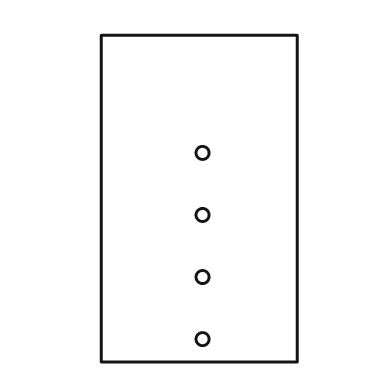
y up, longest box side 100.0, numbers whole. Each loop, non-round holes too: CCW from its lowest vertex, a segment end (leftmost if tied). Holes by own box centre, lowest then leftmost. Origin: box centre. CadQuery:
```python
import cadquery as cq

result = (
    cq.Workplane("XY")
    .moveTo(-30.0, -50.0)
    .lineTo(30.0, -50.0)
    .lineTo(30.0, 50.0)
    .lineTo(-30.0, 50.0)
    .close()
    .moveTo(1.0, -43.0)
    .circle(2.0)
    .moveTo(1.0, -24.0)
    .circle(2.0)
    .moveTo(1.0, -5.0)
    .circle(2.0)
    .moveTo(1.0, 14.0)
    .circle(2.0)
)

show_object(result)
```